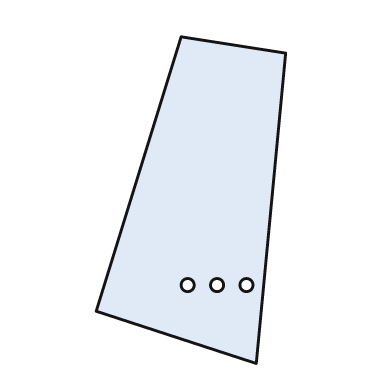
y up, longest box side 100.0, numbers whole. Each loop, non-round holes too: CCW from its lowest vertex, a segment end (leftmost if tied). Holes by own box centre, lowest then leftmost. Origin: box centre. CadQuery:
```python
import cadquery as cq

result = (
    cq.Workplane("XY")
    .moveTo(20.0, -50.0)
    .lineTo(29.0, 45.0)
    .lineTo(-3.0, 50.0)
    .lineTo(-29.0, -34.0)
    .close()
    .moveTo(-1.0, -26.0)
    .circle(2.0)
    .moveTo(8.0, -26.0)
    .circle(2.0)
    .moveTo(17.0, -26.0)
    .circle(2.0)
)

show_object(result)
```